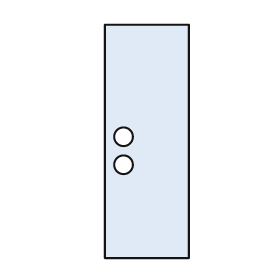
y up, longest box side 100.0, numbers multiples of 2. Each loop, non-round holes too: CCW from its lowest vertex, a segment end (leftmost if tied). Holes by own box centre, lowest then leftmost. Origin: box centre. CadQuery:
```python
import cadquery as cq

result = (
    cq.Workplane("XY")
    .moveTo(-18.0, -50.0)
    .lineTo(18.0, -50.0)
    .lineTo(18.0, 50.0)
    .lineTo(-18.0, 50.0)
    .close()
    .moveTo(-10.0, -10.0)
    .circle(4.0)
    .moveTo(-10.0, 2.0)
    .circle(4.0)
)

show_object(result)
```